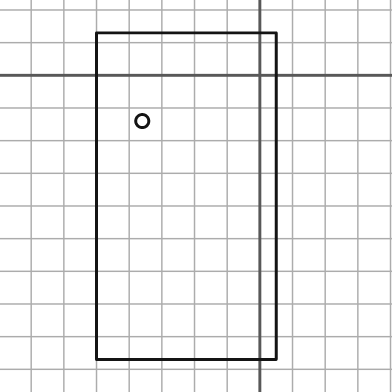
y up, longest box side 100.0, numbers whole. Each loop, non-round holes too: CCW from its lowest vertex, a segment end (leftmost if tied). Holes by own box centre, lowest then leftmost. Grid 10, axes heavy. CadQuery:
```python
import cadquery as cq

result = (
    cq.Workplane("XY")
    .moveTo(-50.0, -87.0)
    .lineTo(5.0, -87.0)
    .lineTo(5.0, 13.0)
    .lineTo(-50.0, 13.0)
    .close()
    .moveTo(-36.0, -14.0)
    .circle(2.0)
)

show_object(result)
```